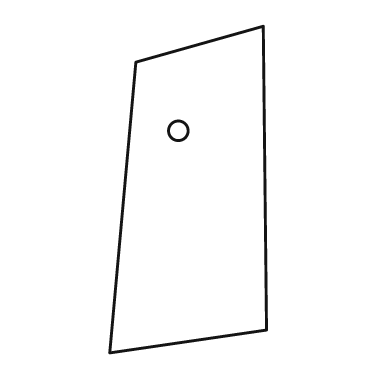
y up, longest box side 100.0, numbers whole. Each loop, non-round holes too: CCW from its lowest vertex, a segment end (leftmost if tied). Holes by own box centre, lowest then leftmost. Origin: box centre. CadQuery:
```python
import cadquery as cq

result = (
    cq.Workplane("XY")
    .moveTo(-24.0, -50.0)
    .lineTo(24.0, -43.0)
    .lineTo(23.0, 50.0)
    .lineTo(-16.0, 39.0)
    .close()
    .moveTo(-3.0, 18.0)
    .circle(3.0)
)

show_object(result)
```